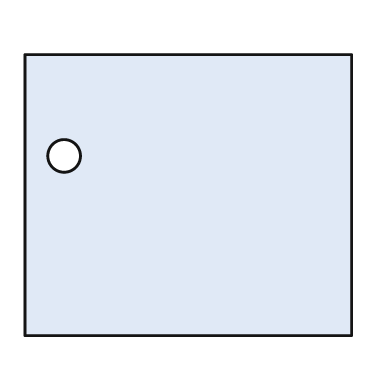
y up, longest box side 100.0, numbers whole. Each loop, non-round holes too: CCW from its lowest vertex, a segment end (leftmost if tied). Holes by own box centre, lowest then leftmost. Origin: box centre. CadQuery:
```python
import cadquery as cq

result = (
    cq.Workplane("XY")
    .moveTo(-50.0, -43.0)
    .lineTo(50.0, -43.0)
    .lineTo(50.0, 43.0)
    .lineTo(-50.0, 43.0)
    .close()
    .moveTo(-38.0, 12.0)
    .circle(5.0)
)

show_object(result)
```